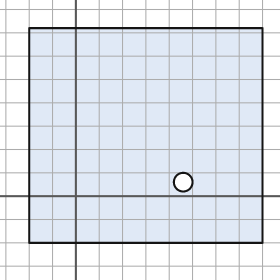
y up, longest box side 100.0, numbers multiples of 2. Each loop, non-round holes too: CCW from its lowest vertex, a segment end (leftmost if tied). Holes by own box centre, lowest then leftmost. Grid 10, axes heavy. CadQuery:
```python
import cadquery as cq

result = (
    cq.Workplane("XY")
    .moveTo(-20.0, -20.0)
    .lineTo(80.0, -20.0)
    .lineTo(80.0, 72.0)
    .lineTo(-20.0, 72.0)
    .close()
    .moveTo(46.0, 6.0)
    .circle(4.0)
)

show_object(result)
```